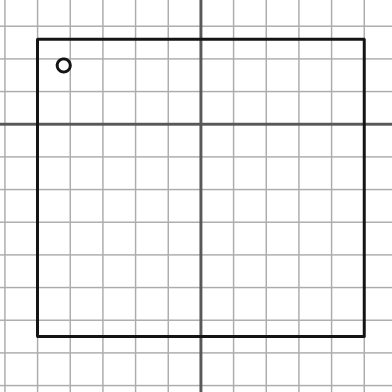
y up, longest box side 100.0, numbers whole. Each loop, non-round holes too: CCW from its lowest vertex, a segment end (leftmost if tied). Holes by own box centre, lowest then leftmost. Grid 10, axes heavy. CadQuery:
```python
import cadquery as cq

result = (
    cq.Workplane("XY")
    .moveTo(-50.0, -65.0)
    .lineTo(50.0, -65.0)
    .lineTo(50.0, 26.0)
    .lineTo(-50.0, 26.0)
    .close()
    .moveTo(-42.0, 18.0)
    .circle(2.0)
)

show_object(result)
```